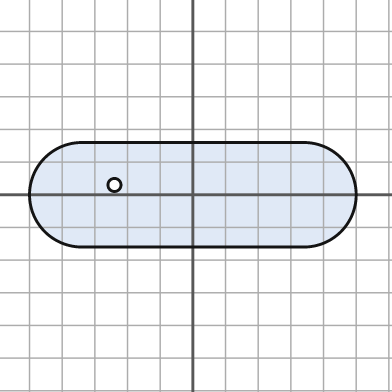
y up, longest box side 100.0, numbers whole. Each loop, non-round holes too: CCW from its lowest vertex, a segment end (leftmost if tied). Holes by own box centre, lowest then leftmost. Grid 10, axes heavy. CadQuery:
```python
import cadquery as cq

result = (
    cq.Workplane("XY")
    .moveTo(-34.0, -16.0)
    .lineTo(34.0, -16.0)
    .threePointArc((50.0, 0.0), (34.0, 16.0))
    .lineTo(-34.0, 16.0)
    .threePointArc((-50.0, 0.0), (-34.0, -16.0))
    .close()
    .moveTo(-24.0, 3.0)
    .circle(2.0)
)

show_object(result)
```